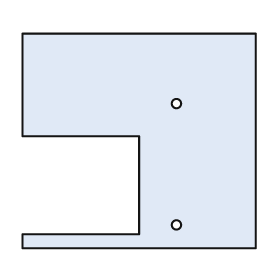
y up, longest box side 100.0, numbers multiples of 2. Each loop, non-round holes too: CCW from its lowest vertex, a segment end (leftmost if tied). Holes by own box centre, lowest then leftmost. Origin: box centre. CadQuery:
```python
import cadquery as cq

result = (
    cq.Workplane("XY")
    .moveTo(-50.0, -46.0)
    .lineTo(50.0, -46.0)
    .lineTo(50.0, 46.0)
    .lineTo(-50.0, 46.0)
    .lineTo(-50.0, 2.0)
    .lineTo(0.0, 2.0)
    .lineTo(0.0, -40.0)
    .lineTo(-50.0, -40.0)
    .close()
    .moveTo(16.0, -36.0)
    .circle(2.0)
    .moveTo(16.0, 16.0)
    .circle(2.0)
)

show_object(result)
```